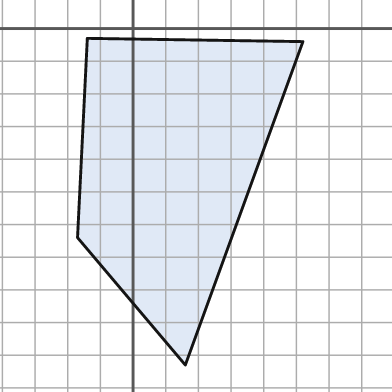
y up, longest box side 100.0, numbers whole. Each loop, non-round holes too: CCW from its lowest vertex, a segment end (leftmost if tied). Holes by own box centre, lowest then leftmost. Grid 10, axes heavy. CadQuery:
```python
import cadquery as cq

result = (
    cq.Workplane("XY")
    .moveTo(16.0, -103.0)
    .lineTo(52.0, -4.0)
    .lineTo(-14.0, -3.0)
    .lineTo(-17.0, -64.0)
    .close()
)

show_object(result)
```